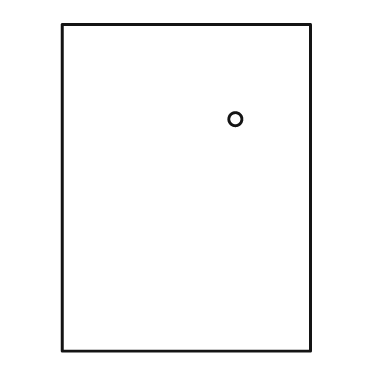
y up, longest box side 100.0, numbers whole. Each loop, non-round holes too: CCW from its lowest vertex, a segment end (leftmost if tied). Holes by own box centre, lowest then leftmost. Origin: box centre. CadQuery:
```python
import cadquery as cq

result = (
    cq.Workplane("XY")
    .moveTo(-38.0, -50.0)
    .lineTo(38.0, -50.0)
    .lineTo(38.0, 50.0)
    .lineTo(-38.0, 50.0)
    .close()
    .moveTo(15.0, 21.0)
    .circle(2.0)
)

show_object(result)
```